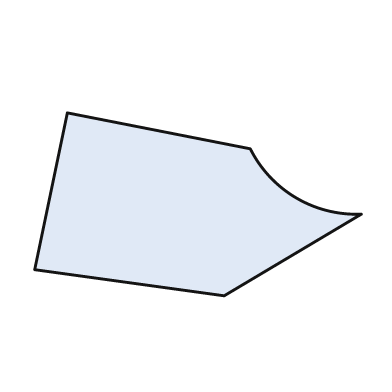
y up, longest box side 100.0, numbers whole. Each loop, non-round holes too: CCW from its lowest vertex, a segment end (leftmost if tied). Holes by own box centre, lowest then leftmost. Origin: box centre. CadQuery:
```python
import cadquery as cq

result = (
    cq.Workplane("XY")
    .moveTo(8.0, -28.0)
    .lineTo(50.0, -3.0)
    .threePointArc((30.0, 2.0), (16.0, 17.0))
    .lineTo(-40.0, 28.0)
    .lineTo(-50.0, -20.0)
    .close()
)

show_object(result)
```